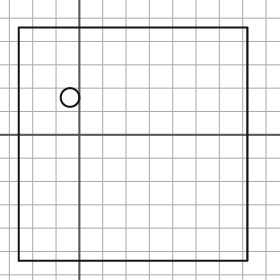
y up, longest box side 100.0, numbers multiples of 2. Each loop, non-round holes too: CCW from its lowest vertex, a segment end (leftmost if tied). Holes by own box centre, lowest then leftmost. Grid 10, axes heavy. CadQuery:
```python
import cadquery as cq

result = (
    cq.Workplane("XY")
    .moveTo(-26.0, -54.0)
    .lineTo(72.0, -54.0)
    .lineTo(72.0, 46.0)
    .lineTo(-26.0, 46.0)
    .close()
    .moveTo(-4.0, 16.0)
    .circle(4.0)
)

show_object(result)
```